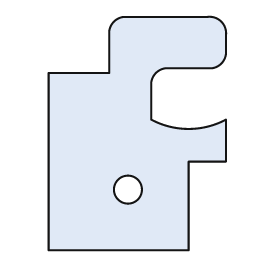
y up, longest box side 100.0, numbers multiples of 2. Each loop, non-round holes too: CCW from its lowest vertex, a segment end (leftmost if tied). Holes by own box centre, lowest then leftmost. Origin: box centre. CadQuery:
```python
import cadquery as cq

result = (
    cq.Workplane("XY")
    .moveTo(-38.0, -50.0)
    .lineTo(22.0, -50.0)
    .lineTo(22.0, -12.0)
    .lineTo(38.0, -12.0)
    .lineTo(38.0, 6.0)
    .threePointArc((22.0, 2.0), (6.0, 6.0))
    .lineTo(6.0, 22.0)
    .threePointArc((8.0, 26.0), (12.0, 28.0))
    .lineTo(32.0, 28.0)
    .threePointArc((36.0, 30.0), (38.0, 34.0))
    .lineTo(38.0, 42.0)
    .threePointArc((36.0, 48.0), (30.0, 50.0))
    .lineTo(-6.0, 50.0)
    .threePointArc((-10.0, 48.0), (-12.0, 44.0))
    .lineTo(-12.0, 26.0)
    .lineTo(-38.0, 26.0)
    .close()
    .moveTo(-4.0, -24.0)
    .circle(6.0)
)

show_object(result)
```